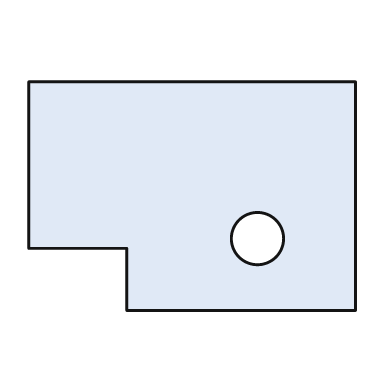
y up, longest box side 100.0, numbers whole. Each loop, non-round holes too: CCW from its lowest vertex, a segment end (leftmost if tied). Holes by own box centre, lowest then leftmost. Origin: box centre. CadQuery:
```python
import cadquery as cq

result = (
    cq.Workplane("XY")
    .moveTo(-20.0, -35.0)
    .lineTo(50.0, -35.0)
    .lineTo(50.0, 35.0)
    .lineTo(-50.0, 35.0)
    .lineTo(-50.0, -16.0)
    .lineTo(-20.0, -16.0)
    .close()
    .moveTo(20.0, -13.0)
    .circle(8.0)
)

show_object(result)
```